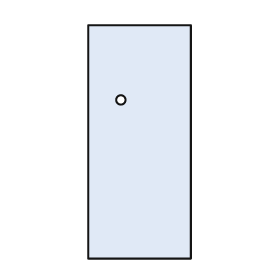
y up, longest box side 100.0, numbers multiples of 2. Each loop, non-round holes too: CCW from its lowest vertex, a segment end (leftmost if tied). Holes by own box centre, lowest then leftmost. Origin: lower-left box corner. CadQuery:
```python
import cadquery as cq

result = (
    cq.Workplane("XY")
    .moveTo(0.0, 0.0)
    .lineTo(44.0, 0.0)
    .lineTo(44.0, 100.0)
    .lineTo(0.0, 100.0)
    .close()
    .moveTo(14.0, 68.0)
    .circle(2.0)
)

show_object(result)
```